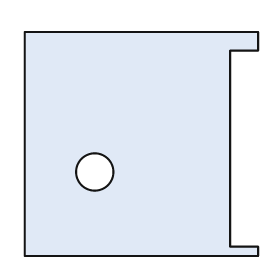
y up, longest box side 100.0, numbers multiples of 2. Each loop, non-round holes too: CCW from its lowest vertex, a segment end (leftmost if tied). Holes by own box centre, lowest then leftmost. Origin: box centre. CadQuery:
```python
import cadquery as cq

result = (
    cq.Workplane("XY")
    .moveTo(-50.0, -48.0)
    .lineTo(50.0, -48.0)
    .lineTo(50.0, -44.0)
    .lineTo(38.0, -44.0)
    .lineTo(38.0, 40.0)
    .lineTo(50.0, 40.0)
    .lineTo(50.0, 48.0)
    .lineTo(-50.0, 48.0)
    .close()
    .moveTo(-20.0, -12.0)
    .circle(8.0)
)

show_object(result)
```